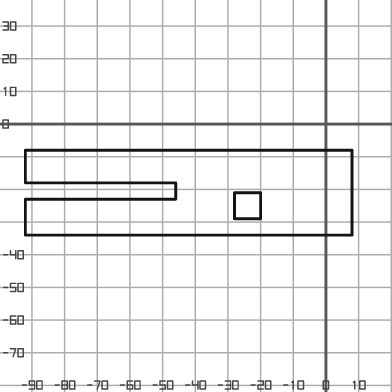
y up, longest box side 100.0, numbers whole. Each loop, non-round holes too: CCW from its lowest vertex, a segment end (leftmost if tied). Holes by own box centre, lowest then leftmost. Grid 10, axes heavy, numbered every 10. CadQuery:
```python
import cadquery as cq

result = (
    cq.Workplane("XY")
    .moveTo(-92.0, -34.0)
    .lineTo(8.0, -34.0)
    .lineTo(8.0, -8.0)
    .lineTo(-92.0, -8.0)
    .lineTo(-92.0, -18.0)
    .lineTo(-46.0, -18.0)
    .lineTo(-46.0, -23.0)
    .lineTo(-92.0, -23.0)
    .close()
    .moveTo(-28.0, -29.0)
    .lineTo(-20.0, -29.0)
    .lineTo(-20.0, -21.0)
    .lineTo(-28.0, -21.0)
    .close()
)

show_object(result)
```